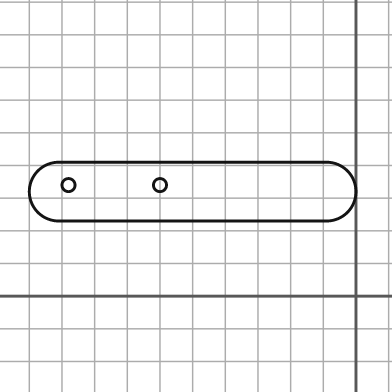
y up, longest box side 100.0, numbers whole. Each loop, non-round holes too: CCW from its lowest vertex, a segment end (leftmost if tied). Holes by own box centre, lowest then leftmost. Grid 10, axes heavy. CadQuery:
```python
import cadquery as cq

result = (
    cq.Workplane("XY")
    .moveTo(-91.0, 23.0)
    .lineTo(-9.0, 23.0)
    .threePointArc((0.0, 32.0), (-9.0, 41.0))
    .lineTo(-91.0, 41.0)
    .threePointArc((-100.0, 32.0), (-91.0, 23.0))
    .close()
    .moveTo(-88.0, 34.0)
    .circle(2.0)
    .moveTo(-60.0, 34.0)
    .circle(2.0)
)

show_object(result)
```